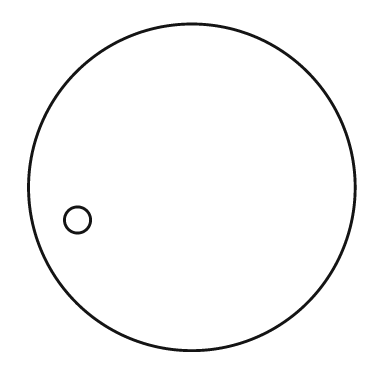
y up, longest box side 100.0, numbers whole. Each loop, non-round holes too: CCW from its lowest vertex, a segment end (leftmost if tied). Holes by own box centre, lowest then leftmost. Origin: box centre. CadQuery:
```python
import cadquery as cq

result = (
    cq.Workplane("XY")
    .moveTo(0.0, 0.0)
    .circle(50.0)
    .moveTo(-35.0, -10.0)
    .circle(4.0)
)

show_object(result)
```